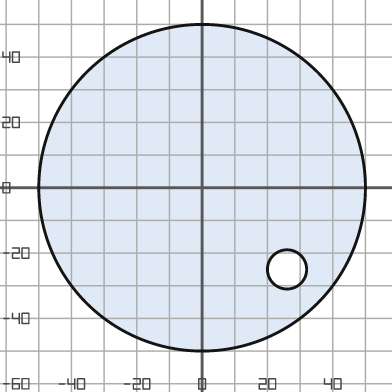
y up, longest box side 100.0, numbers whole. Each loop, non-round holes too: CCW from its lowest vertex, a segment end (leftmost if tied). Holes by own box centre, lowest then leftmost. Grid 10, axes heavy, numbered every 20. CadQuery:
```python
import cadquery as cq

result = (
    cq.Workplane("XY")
    .moveTo(0.0, 0.0)
    .circle(50.0)
    .moveTo(26.0, -25.0)
    .circle(6.0)
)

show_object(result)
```